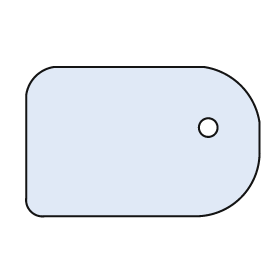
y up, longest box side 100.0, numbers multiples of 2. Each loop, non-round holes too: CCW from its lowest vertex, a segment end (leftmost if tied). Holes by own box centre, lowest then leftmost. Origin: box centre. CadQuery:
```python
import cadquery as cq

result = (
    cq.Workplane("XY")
    .moveTo(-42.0, -32.0)
    .lineTo(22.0, -32.0)
    .threePointArc((42.0, -24.0), (50.0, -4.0))
    .lineTo(50.0, 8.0)
    .threePointArc((42.0, 24.0), (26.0, 32.0))
    .lineTo(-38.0, 32.0)
    .threePointArc((-46.0, 28.0), (-50.0, 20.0))
    .lineTo(-50.0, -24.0)
    .threePointArc((-48.0, -30.0), (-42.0, -32.0))
    .close()
    .moveTo(28.0, 6.0)
    .circle(4.0)
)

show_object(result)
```